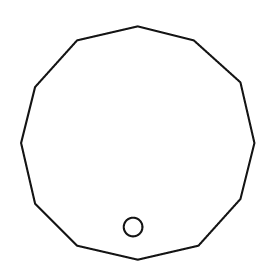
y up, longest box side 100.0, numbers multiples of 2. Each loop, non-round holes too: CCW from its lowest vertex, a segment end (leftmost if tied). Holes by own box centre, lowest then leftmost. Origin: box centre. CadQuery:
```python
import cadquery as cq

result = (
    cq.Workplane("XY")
    .moveTo(0.0, -50.0)
    .lineTo(26.0, -44.0)
    .lineTo(44.0, -24.0)
    .lineTo(50.0, 0.0)
    .lineTo(44.0, 26.0)
    .lineTo(24.0, 44.0)
    .lineTo(0.0, 50.0)
    .lineTo(-26.0, 44.0)
    .lineTo(-44.0, 24.0)
    .lineTo(-50.0, 0.0)
    .lineTo(-44.0, -26.0)
    .lineTo(-26.0, -44.0)
    .close()
    .moveTo(-2.0, -36.0)
    .circle(4.0)
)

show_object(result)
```